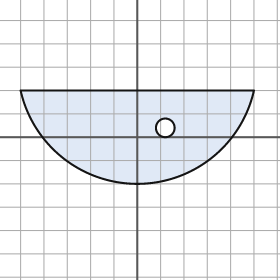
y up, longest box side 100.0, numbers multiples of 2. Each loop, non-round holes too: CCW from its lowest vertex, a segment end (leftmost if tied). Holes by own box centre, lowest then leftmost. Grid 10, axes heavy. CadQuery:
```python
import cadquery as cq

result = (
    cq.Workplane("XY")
    .moveTo(-50.0, 20.0)
    .threePointArc((0.0, -20.0), (50.0, 20.0))
    .close()
    .moveTo(12.0, 4.0)
    .circle(4.0)
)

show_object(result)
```